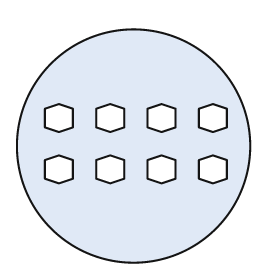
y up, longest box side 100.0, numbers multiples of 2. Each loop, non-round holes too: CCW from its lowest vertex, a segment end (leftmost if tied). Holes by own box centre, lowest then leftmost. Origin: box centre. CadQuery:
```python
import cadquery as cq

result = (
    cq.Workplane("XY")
    .moveTo(0.0, 0.0)
    .circle(50.0)
    .moveTo(-32.0, -16.0)
    .lineTo(-26.0, -14.0)
    .lineTo(-26.0, -6.0)
    .lineTo(-32.0, -4.0)
    .lineTo(-38.0, -6.0)
    .lineTo(-38.0, -14.0)
    .close()
    .moveTo(-10.0, -16.0)
    .lineTo(-4.0, -14.0)
    .lineTo(-4.0, -6.0)
    .lineTo(-10.0, -4.0)
    .lineTo(-16.0, -6.0)
    .lineTo(-16.0, -14.0)
    .close()
    .moveTo(12.0, -16.0)
    .lineTo(18.0, -14.0)
    .lineTo(18.0, -6.0)
    .lineTo(12.0, -4.0)
    .lineTo(6.0, -6.0)
    .lineTo(6.0, -14.0)
    .close()
    .moveTo(34.0, -16.0)
    .lineTo(40.0, -14.0)
    .lineTo(40.0, -6.0)
    .lineTo(34.0, -4.0)
    .lineTo(28.0, -6.0)
    .lineTo(28.0, -14.0)
    .close()
    .moveTo(-32.0, 6.0)
    .lineTo(-26.0, 8.0)
    .lineTo(-26.0, 16.0)
    .lineTo(-32.0, 18.0)
    .lineTo(-38.0, 16.0)
    .lineTo(-38.0, 8.0)
    .close()
    .moveTo(-10.0, 6.0)
    .lineTo(-4.0, 8.0)
    .lineTo(-4.0, 16.0)
    .lineTo(-10.0, 18.0)
    .lineTo(-16.0, 16.0)
    .lineTo(-16.0, 8.0)
    .close()
    .moveTo(12.0, 6.0)
    .lineTo(18.0, 8.0)
    .lineTo(18.0, 16.0)
    .lineTo(12.0, 18.0)
    .lineTo(6.0, 16.0)
    .lineTo(6.0, 8.0)
    .close()
    .moveTo(34.0, 6.0)
    .lineTo(40.0, 8.0)
    .lineTo(40.0, 16.0)
    .lineTo(34.0, 18.0)
    .lineTo(28.0, 16.0)
    .lineTo(28.0, 8.0)
    .close()
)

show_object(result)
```